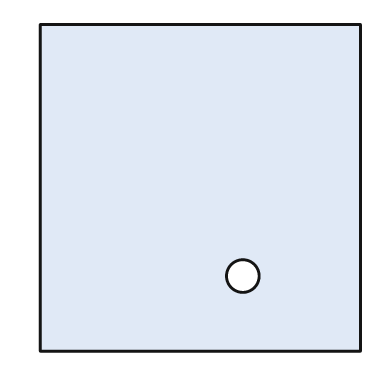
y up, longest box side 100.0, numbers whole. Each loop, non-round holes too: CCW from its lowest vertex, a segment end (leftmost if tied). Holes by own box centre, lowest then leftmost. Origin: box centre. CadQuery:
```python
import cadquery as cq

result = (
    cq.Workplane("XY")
    .moveTo(-49.0, -50.0)
    .lineTo(49.0, -50.0)
    .lineTo(49.0, 50.0)
    .lineTo(-49.0, 50.0)
    .close()
    .moveTo(13.0, -27.0)
    .circle(5.0)
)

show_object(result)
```